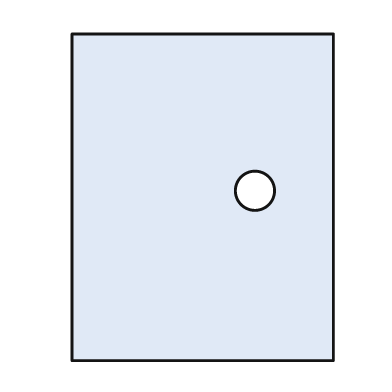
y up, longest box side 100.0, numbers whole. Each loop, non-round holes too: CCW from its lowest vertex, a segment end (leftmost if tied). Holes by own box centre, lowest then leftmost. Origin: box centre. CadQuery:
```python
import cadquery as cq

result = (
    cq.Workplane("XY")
    .moveTo(-40.0, -50.0)
    .lineTo(40.0, -50.0)
    .lineTo(40.0, 50.0)
    .lineTo(-40.0, 50.0)
    .close()
    .moveTo(16.0, 2.0)
    .circle(6.0)
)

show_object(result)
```